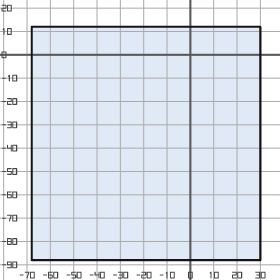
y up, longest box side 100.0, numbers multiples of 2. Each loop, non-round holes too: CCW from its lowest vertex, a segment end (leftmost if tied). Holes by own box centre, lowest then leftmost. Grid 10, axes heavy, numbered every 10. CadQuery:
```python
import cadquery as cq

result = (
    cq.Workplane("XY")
    .moveTo(-68.0, -88.0)
    .lineTo(30.0, -88.0)
    .lineTo(30.0, 12.0)
    .lineTo(-68.0, 12.0)
    .close()
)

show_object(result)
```